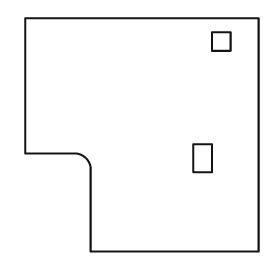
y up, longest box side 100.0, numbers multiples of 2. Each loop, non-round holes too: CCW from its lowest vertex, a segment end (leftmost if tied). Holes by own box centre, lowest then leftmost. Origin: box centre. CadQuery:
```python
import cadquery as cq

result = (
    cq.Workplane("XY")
    .moveTo(-22.0, -50.0)
    .lineTo(50.0, -50.0)
    .lineTo(50.0, 50.0)
    .lineTo(-50.0, 50.0)
    .lineTo(-50.0, -8.0)
    .lineTo(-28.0, -8.0)
    .threePointArc((-24.0, -10.0), (-22.0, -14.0))
    .close()
    .moveTo(22.0, -16.0)
    .lineTo(30.0, -16.0)
    .lineTo(30.0, -4.0)
    .lineTo(22.0, -4.0)
    .close()
    .moveTo(30.0, 36.0)
    .lineTo(38.0, 36.0)
    .lineTo(38.0, 44.0)
    .lineTo(30.0, 44.0)
    .close()
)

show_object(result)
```